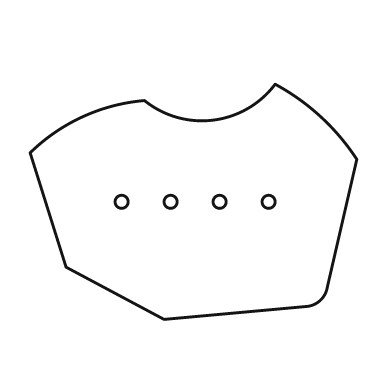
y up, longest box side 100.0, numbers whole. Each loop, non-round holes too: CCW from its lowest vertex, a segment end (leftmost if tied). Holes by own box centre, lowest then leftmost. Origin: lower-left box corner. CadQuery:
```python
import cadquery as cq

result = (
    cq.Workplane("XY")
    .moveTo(41.0, 0.0)
    .lineTo(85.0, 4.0)
    .threePointArc((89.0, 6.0), (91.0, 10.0))
    .lineTo(100.0, 49.0)
    .threePointArc((89.0, 62.0), (75.0, 72.0))
    .threePointArc((56.0, 61.0), (35.0, 67.0))
    .threePointArc((16.0, 62.0), (0.0, 51.0))
    .lineTo(11.0, 16.0)
    .close()
    .moveTo(28.0, 36.0)
    .circle(2.0)
    .moveTo(43.0, 36.0)
    .circle(2.0)
    .moveTo(58.0, 36.0)
    .circle(2.0)
    .moveTo(73.0, 36.0)
    .circle(2.0)
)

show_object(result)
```